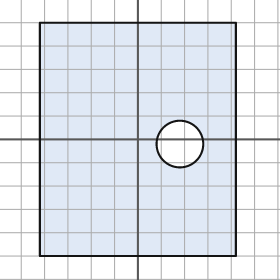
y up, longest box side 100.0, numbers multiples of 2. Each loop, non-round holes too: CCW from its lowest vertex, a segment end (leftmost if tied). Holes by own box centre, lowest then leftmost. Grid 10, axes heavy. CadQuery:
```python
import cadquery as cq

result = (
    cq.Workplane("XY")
    .moveTo(-42.0, -50.0)
    .lineTo(42.0, -50.0)
    .lineTo(42.0, 50.0)
    .lineTo(-42.0, 50.0)
    .close()
    .moveTo(18.0, -2.0)
    .circle(10.0)
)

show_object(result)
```